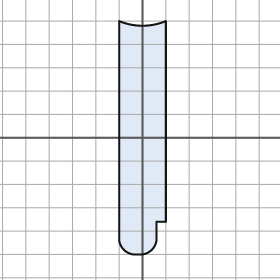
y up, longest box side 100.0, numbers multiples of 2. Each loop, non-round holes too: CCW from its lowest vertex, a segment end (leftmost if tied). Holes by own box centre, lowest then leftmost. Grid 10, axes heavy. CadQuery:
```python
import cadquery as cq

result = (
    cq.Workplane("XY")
    .moveTo(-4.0, -50.0)
    .lineTo(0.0, -50.0)
    .threePointArc((4.0, -48.0), (6.0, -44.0))
    .lineTo(6.0, -36.0)
    .lineTo(10.0, -36.0)
    .lineTo(10.0, 50.0)
    .threePointArc((0.0, 48.0), (-10.0, 50.0))
    .lineTo(-10.0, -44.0)
    .threePointArc((-8.0, -48.0), (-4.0, -50.0))
    .close()
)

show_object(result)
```